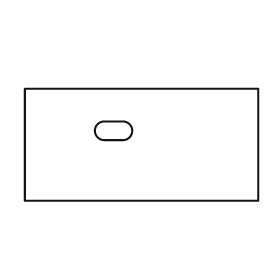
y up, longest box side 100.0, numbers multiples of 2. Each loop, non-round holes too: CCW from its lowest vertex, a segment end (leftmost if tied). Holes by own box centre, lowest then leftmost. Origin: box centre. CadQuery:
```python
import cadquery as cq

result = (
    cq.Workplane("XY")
    .moveTo(-50.0, -24.0)
    .lineTo(50.0, -24.0)
    .lineTo(50.0, 24.0)
    .lineTo(-50.0, 24.0)
    .close()
    .moveTo(-16.0, 2.0)
    .lineTo(-8.0, 2.0)
    .threePointArc((-4.0, 6.0), (-8.0, 10.0))
    .lineTo(-16.0, 10.0)
    .threePointArc((-20.0, 6.0), (-16.0, 2.0))
    .close()
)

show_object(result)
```